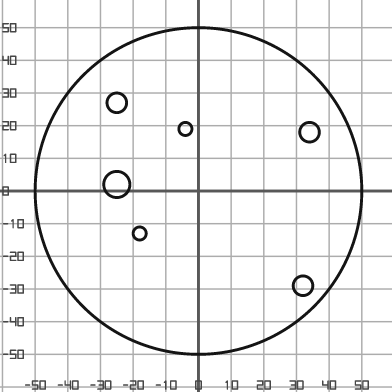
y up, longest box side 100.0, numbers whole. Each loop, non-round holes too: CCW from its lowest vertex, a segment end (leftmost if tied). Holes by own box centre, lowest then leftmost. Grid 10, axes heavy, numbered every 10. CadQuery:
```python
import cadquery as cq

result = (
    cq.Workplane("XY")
    .moveTo(0.0, 0.0)
    .circle(50.0)
    .moveTo(32.0, -29.0)
    .circle(3.0)
    .moveTo(-18.0, -13.0)
    .circle(2.0)
    .moveTo(-25.0, 2.0)
    .circle(4.0)
    .moveTo(34.0, 18.0)
    .circle(3.0)
    .moveTo(-4.0, 19.0)
    .circle(2.0)
    .moveTo(-25.0, 27.0)
    .circle(3.0)
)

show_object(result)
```